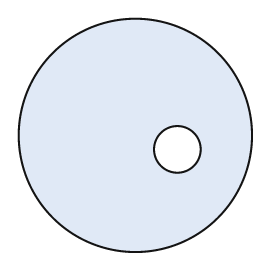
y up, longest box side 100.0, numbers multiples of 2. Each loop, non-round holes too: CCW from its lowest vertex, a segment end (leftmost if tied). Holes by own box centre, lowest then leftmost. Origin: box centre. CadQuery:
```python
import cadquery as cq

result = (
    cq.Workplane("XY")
    .moveTo(0.0, 0.0)
    .circle(50.0)
    .moveTo(18.0, -6.0)
    .circle(10.0)
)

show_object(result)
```